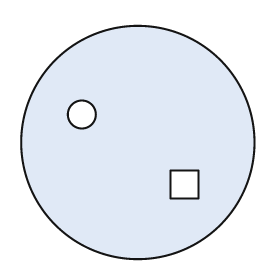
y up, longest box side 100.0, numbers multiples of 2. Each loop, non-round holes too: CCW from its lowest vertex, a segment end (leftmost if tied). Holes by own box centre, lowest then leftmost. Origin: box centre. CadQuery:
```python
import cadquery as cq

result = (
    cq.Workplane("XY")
    .moveTo(0.0, 0.0)
    .circle(50.0)
    .moveTo(14.0, -24.0)
    .lineTo(26.0, -24.0)
    .lineTo(26.0, -12.0)
    .lineTo(14.0, -12.0)
    .close()
    .moveTo(-24.0, 12.0)
    .circle(6.0)
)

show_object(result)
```